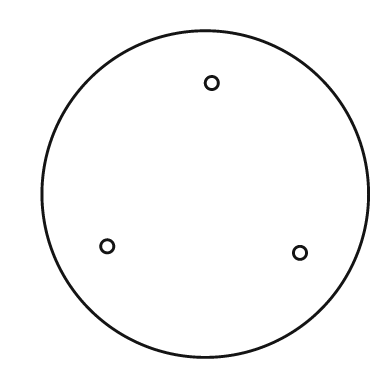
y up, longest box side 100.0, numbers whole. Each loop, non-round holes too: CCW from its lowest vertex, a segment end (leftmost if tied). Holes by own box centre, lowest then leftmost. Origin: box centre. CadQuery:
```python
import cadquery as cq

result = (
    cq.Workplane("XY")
    .moveTo(0.0, 0.0)
    .circle(50.0)
    .moveTo(29.0, -18.0)
    .circle(2.0)
    .moveTo(-30.0, -16.0)
    .circle(2.0)
    .moveTo(2.0, 34.0)
    .circle(2.0)
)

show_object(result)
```